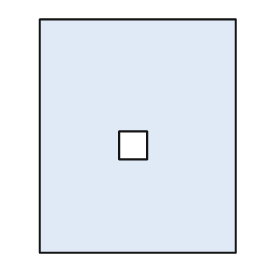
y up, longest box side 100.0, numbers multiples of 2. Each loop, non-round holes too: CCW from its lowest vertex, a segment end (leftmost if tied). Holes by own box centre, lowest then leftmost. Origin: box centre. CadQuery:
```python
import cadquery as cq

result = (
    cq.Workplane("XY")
    .moveTo(-42.0, -50.0)
    .lineTo(42.0, -50.0)
    .lineTo(42.0, 50.0)
    .lineTo(-42.0, 50.0)
    .close()
    .moveTo(-8.0, -10.0)
    .lineTo(4.0, -10.0)
    .lineTo(4.0, 2.0)
    .lineTo(-8.0, 2.0)
    .close()
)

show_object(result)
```